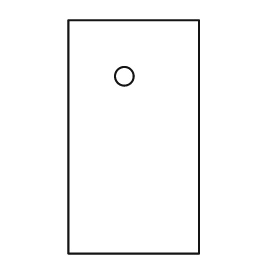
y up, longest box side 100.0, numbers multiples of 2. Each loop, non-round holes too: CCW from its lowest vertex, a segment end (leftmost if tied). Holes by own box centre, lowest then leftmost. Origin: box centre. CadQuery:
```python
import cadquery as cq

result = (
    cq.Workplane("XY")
    .moveTo(-28.0, -50.0)
    .lineTo(28.0, -50.0)
    .lineTo(28.0, 50.0)
    .lineTo(-28.0, 50.0)
    .close()
    .moveTo(-4.0, 26.0)
    .circle(4.0)
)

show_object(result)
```